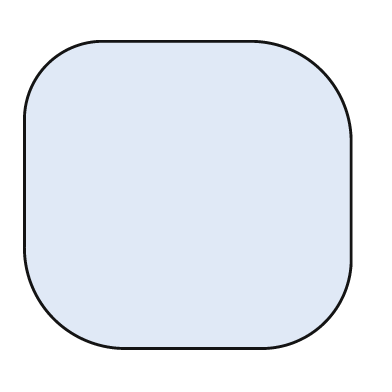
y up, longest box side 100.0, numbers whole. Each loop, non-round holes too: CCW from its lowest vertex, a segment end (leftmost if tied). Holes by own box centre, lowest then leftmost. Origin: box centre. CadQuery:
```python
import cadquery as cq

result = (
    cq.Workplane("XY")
    .moveTo(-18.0, -47.0)
    .lineTo(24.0, -47.0)
    .threePointArc((42.0, -39.0), (50.0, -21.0))
    .lineTo(50.0, 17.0)
    .threePointArc((41.0, 38.0), (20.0, 47.0))
    .lineTo(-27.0, 47.0)
    .threePointArc((-43.0, 40.0), (-50.0, 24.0))
    .lineTo(-50.0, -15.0)
    .threePointArc((-41.0, -38.0), (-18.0, -47.0))
    .close()
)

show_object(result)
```